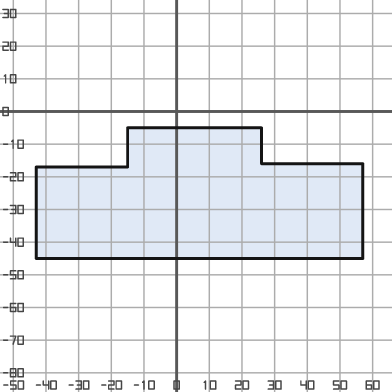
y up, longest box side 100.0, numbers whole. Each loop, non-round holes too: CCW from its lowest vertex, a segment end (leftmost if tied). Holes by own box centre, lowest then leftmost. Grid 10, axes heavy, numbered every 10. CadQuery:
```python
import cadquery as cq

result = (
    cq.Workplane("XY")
    .moveTo(-43.0, -45.0)
    .lineTo(57.0, -45.0)
    .lineTo(57.0, -16.0)
    .lineTo(26.0, -16.0)
    .lineTo(26.0, -5.0)
    .lineTo(-15.0, -5.0)
    .lineTo(-15.0, -17.0)
    .lineTo(-43.0, -17.0)
    .close()
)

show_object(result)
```